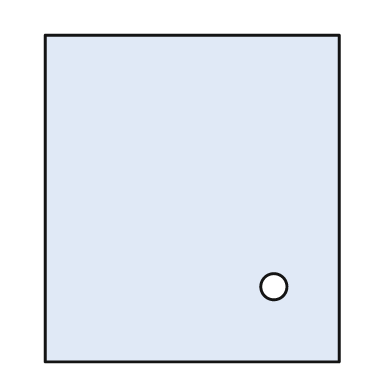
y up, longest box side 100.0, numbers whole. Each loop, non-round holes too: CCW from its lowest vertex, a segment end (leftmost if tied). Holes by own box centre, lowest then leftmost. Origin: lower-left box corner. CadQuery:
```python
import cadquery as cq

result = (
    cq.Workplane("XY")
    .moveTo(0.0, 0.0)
    .lineTo(90.0, 0.0)
    .lineTo(90.0, 100.0)
    .lineTo(0.0, 100.0)
    .close()
    .moveTo(70.0, 23.0)
    .circle(4.0)
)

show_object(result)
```